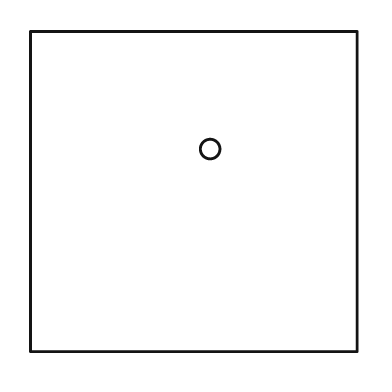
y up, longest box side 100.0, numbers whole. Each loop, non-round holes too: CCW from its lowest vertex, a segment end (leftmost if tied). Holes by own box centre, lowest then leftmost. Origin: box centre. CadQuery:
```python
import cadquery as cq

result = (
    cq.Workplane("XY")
    .moveTo(-50.0, -49.0)
    .lineTo(50.0, -49.0)
    .lineTo(50.0, 49.0)
    .lineTo(-50.0, 49.0)
    .close()
    .moveTo(5.0, 13.0)
    .circle(3.0)
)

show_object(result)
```